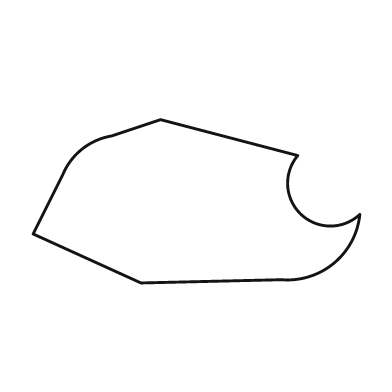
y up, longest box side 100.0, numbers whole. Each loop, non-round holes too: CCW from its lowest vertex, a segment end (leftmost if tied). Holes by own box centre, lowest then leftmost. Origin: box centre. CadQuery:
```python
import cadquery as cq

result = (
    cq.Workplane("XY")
    .moveTo(-17.0, -25.0)
    .lineTo(26.0, -24.0)
    .threePointArc((42.0, -19.0), (50.0, -4.0))
    .threePointArc((32.0, -4.0), (31.0, 14.0))
    .lineTo(-11.0, 25.0)
    .lineTo(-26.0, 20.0)
    .threePointArc((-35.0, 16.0), (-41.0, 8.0))
    .lineTo(-50.0, -10.0)
    .close()
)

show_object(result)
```